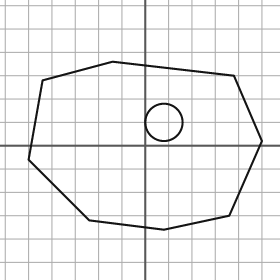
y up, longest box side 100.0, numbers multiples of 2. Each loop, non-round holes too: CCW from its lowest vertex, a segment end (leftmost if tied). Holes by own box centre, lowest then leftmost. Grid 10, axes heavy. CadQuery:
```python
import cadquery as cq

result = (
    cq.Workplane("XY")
    .moveTo(8.0, -36.0)
    .lineTo(36.0, -30.0)
    .lineTo(50.0, 2.0)
    .lineTo(38.0, 30.0)
    .lineTo(-14.0, 36.0)
    .lineTo(-44.0, 28.0)
    .lineTo(-50.0, -6.0)
    .lineTo(-24.0, -32.0)
    .close()
    .moveTo(8.0, 10.0)
    .circle(8.0)
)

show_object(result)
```